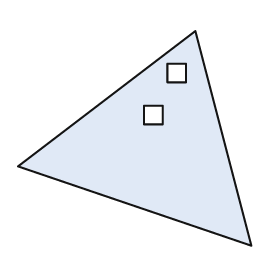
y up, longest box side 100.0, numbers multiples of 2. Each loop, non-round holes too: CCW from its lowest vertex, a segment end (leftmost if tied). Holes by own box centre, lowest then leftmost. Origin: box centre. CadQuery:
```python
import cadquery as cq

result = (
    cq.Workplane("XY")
    .moveTo(50.0, -46.0)
    .lineTo(26.0, 46.0)
    .lineTo(-50.0, -12.0)
    .close()
    .moveTo(4.0, 6.0)
    .lineTo(12.0, 6.0)
    .lineTo(12.0, 14.0)
    .lineTo(4.0, 14.0)
    .close()
    .moveTo(14.0, 24.0)
    .lineTo(22.0, 24.0)
    .lineTo(22.0, 32.0)
    .lineTo(14.0, 32.0)
    .close()
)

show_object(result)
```